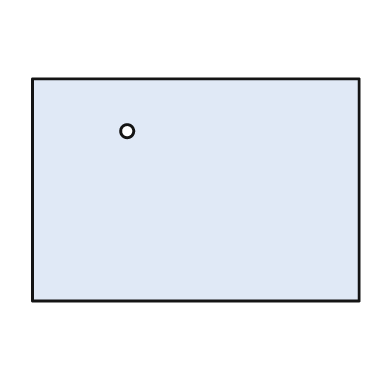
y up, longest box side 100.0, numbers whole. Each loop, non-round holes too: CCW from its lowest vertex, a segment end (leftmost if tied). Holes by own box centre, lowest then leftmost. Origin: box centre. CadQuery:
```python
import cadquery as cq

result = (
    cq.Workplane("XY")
    .moveTo(-50.0, -34.0)
    .lineTo(50.0, -34.0)
    .lineTo(50.0, 34.0)
    .lineTo(-50.0, 34.0)
    .close()
    .moveTo(-21.0, 18.0)
    .circle(2.0)
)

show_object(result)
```